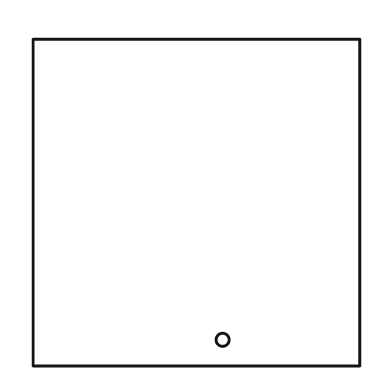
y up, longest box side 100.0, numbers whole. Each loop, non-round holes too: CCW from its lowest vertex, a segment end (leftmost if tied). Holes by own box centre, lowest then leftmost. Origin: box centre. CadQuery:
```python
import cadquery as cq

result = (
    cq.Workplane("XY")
    .moveTo(-50.0, -50.0)
    .lineTo(50.0, -50.0)
    .lineTo(50.0, 50.0)
    .lineTo(-50.0, 50.0)
    .close()
    .moveTo(8.0, -42.0)
    .circle(2.0)
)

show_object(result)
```